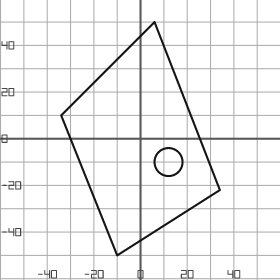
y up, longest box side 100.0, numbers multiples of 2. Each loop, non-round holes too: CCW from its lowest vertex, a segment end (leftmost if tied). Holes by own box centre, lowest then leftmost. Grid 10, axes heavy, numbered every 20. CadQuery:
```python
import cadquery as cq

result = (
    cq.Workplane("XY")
    .moveTo(-10.0, -50.0)
    .lineTo(34.0, -22.0)
    .lineTo(6.0, 50.0)
    .lineTo(-34.0, 10.0)
    .close()
    .moveTo(12.0, -10.0)
    .circle(6.0)
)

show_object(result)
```